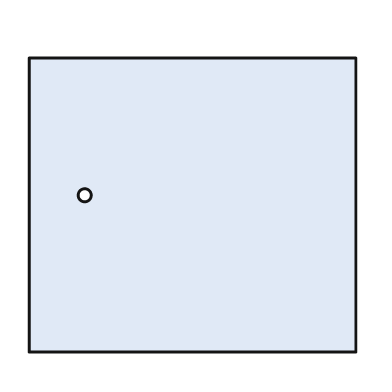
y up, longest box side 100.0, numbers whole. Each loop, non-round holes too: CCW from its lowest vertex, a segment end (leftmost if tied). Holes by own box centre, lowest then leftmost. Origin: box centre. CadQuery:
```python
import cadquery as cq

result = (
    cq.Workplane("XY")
    .moveTo(-50.0, -45.0)
    .lineTo(50.0, -45.0)
    .lineTo(50.0, 45.0)
    .lineTo(-50.0, 45.0)
    .close()
    .moveTo(-33.0, 3.0)
    .circle(2.0)
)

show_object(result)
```